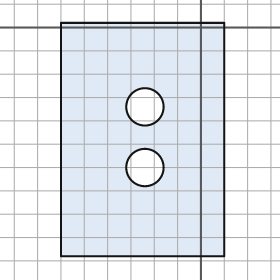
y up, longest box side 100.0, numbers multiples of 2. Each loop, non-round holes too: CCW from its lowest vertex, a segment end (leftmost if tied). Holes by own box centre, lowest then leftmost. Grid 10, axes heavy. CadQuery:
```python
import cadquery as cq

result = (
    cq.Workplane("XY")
    .moveTo(-60.0, -98.0)
    .lineTo(10.0, -98.0)
    .lineTo(10.0, 2.0)
    .lineTo(-60.0, 2.0)
    .close()
    .moveTo(-24.0, -60.0)
    .circle(8.0)
    .moveTo(-24.0, -34.0)
    .circle(8.0)
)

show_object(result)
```